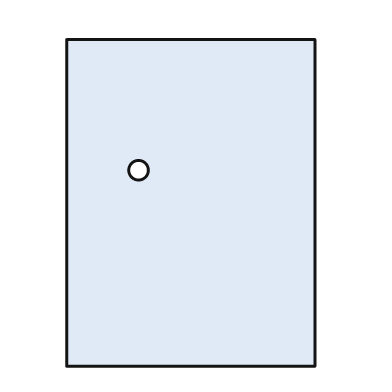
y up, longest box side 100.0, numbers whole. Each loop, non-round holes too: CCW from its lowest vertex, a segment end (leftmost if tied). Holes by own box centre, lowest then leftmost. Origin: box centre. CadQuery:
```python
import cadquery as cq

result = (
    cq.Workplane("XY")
    .moveTo(-38.0, -50.0)
    .lineTo(38.0, -50.0)
    .lineTo(38.0, 50.0)
    .lineTo(-38.0, 50.0)
    .close()
    .moveTo(-16.0, 10.0)
    .circle(3.0)
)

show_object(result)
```